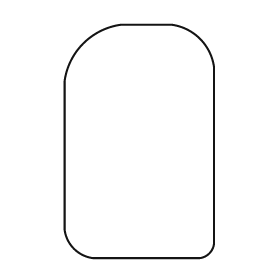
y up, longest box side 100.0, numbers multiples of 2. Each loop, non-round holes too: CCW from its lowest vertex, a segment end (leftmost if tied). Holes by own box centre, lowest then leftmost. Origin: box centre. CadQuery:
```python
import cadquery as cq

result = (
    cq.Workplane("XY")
    .moveTo(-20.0, -50.0)
    .lineTo(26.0, -50.0)
    .threePointArc((30.0, -48.0), (32.0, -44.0))
    .lineTo(32.0, 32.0)
    .threePointArc((26.0, 44.0), (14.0, 50.0))
    .lineTo(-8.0, 50.0)
    .threePointArc((-24.0, 42.0), (-32.0, 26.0))
    .lineTo(-32.0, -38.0)
    .threePointArc((-28.0, -46.0), (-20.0, -50.0))
    .close()
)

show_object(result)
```